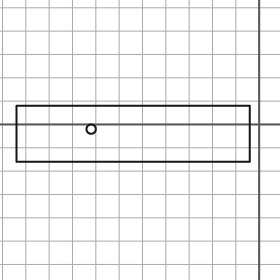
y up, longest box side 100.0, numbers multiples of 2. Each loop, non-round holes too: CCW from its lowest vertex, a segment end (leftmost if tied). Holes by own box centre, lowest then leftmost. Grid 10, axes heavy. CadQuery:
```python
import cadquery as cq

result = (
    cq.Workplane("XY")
    .moveTo(-104.0, -16.0)
    .lineTo(-4.0, -16.0)
    .lineTo(-4.0, 8.0)
    .lineTo(-104.0, 8.0)
    .close()
    .moveTo(-72.0, -2.0)
    .circle(2.0)
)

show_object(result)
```